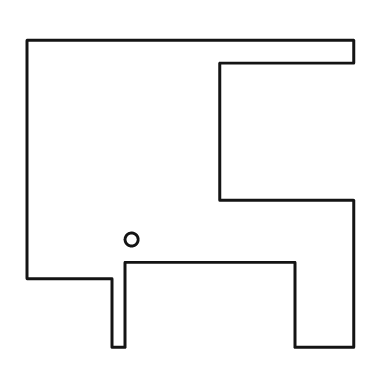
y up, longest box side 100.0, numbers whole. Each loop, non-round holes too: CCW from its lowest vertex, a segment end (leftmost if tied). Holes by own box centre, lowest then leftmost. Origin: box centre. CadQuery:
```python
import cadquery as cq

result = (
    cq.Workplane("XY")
    .moveTo(-24.0, -47.0)
    .lineTo(-20.0, -47.0)
    .lineTo(-20.0, -21.0)
    .lineTo(32.0, -21.0)
    .lineTo(32.0, -47.0)
    .lineTo(50.0, -47.0)
    .lineTo(50.0, -2.0)
    .lineTo(9.0, -2.0)
    .lineTo(9.0, 40.0)
    .lineTo(50.0, 40.0)
    .lineTo(50.0, 47.0)
    .lineTo(-50.0, 47.0)
    .lineTo(-50.0, -26.0)
    .lineTo(-24.0, -26.0)
    .close()
    .moveTo(-18.0, -14.0)
    .circle(2.0)
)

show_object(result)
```